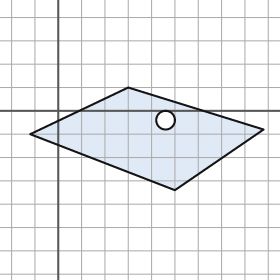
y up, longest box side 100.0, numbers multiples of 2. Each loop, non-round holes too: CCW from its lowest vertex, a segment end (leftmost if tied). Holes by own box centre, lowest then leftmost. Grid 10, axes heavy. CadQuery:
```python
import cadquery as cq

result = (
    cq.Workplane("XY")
    .moveTo(50.0, -34.0)
    .lineTo(88.0, -8.0)
    .lineTo(30.0, 10.0)
    .lineTo(-12.0, -10.0)
    .close()
    .moveTo(46.0, -4.0)
    .circle(4.0)
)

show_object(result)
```